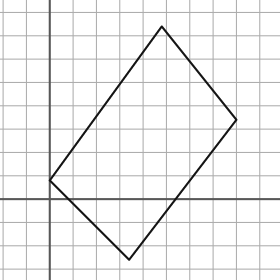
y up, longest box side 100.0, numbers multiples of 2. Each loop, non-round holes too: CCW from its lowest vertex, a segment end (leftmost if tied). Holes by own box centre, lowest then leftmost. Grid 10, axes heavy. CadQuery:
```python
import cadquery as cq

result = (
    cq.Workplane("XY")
    .moveTo(34.0, -26.0)
    .lineTo(80.0, 34.0)
    .lineTo(48.0, 74.0)
    .lineTo(0.0, 8.0)
    .close()
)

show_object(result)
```